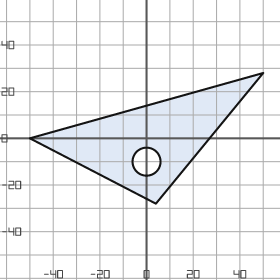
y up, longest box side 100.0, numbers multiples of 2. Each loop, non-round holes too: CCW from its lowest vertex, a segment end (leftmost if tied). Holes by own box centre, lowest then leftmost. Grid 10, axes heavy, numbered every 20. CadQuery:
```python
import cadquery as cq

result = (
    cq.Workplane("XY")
    .moveTo(4.0, -28.0)
    .lineTo(50.0, 28.0)
    .lineTo(-50.0, 0.0)
    .close()
    .moveTo(0.0, -10.0)
    .circle(6.0)
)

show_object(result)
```